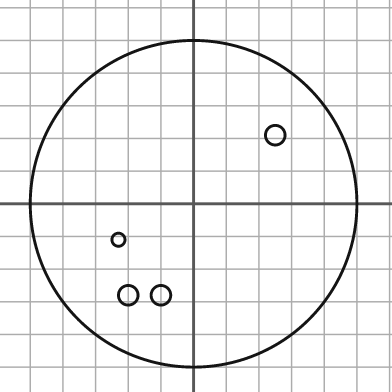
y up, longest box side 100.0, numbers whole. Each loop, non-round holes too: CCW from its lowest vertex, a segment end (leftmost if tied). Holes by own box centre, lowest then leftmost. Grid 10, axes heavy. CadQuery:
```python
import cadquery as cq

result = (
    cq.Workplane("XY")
    .moveTo(0.0, 0.0)
    .circle(50.0)
    .moveTo(-20.0, -28.0)
    .circle(3.0)
    .moveTo(-10.0, -28.0)
    .circle(3.0)
    .moveTo(-23.0, -11.0)
    .circle(2.0)
    .moveTo(25.0, 21.0)
    .circle(3.0)
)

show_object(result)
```